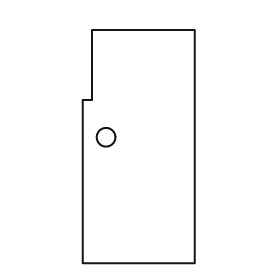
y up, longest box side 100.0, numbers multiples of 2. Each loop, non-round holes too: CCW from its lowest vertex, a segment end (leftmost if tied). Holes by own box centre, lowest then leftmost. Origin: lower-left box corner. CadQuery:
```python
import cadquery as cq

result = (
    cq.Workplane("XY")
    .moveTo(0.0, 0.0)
    .lineTo(48.0, 0.0)
    .lineTo(48.0, 100.0)
    .lineTo(4.0, 100.0)
    .lineTo(4.0, 70.0)
    .lineTo(0.0, 70.0)
    .close()
    .moveTo(10.0, 54.0)
    .circle(4.0)
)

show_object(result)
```